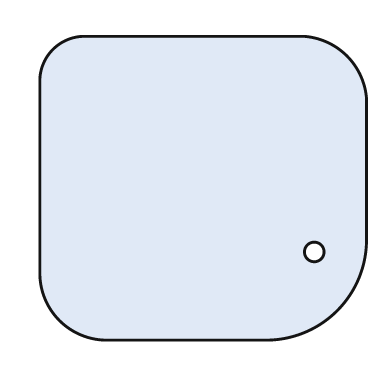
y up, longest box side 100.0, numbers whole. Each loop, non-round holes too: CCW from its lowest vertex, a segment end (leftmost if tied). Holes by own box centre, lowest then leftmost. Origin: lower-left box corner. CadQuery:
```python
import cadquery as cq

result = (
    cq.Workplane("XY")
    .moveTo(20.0, 0.0)
    .lineTo(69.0, 0.0)
    .threePointArc((91.0, 9.0), (100.0, 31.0))
    .lineTo(100.0, 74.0)
    .threePointArc((94.0, 87.0), (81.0, 93.0))
    .lineTo(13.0, 93.0)
    .threePointArc((4.0, 89.0), (0.0, 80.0))
    .lineTo(0.0, 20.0)
    .threePointArc((6.0, 6.0), (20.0, 0.0))
    .close()
    .moveTo(84.0, 27.0)
    .circle(3.0)
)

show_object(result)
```